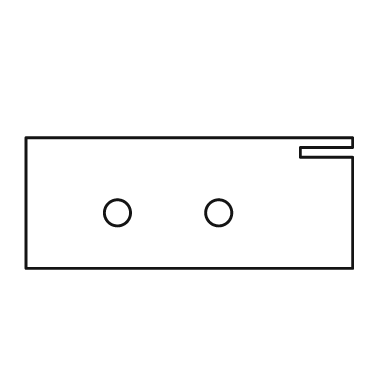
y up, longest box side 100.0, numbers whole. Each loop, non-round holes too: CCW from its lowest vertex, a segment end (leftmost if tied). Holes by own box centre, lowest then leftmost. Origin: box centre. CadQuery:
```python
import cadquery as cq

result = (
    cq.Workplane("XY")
    .moveTo(-50.0, -20.0)
    .lineTo(50.0, -20.0)
    .lineTo(50.0, 14.0)
    .lineTo(34.0, 14.0)
    .lineTo(34.0, 17.0)
    .lineTo(50.0, 17.0)
    .lineTo(50.0, 20.0)
    .lineTo(-50.0, 20.0)
    .close()
    .moveTo(-22.0, -3.0)
    .circle(4.0)
    .moveTo(9.0, -3.0)
    .circle(4.0)
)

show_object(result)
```